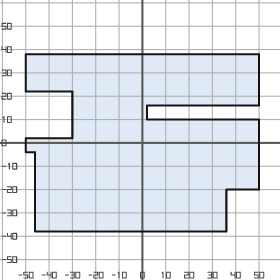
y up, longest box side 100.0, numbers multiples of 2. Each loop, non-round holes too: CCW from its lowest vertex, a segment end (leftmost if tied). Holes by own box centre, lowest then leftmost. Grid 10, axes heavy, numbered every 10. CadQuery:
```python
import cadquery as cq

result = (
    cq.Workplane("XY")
    .moveTo(-46.0, -38.0)
    .lineTo(36.0, -38.0)
    .lineTo(36.0, -20.0)
    .lineTo(50.0, -20.0)
    .lineTo(50.0, 10.0)
    .lineTo(2.0, 10.0)
    .lineTo(2.0, 16.0)
    .lineTo(50.0, 16.0)
    .lineTo(50.0, 38.0)
    .lineTo(-50.0, 38.0)
    .lineTo(-50.0, 22.0)
    .lineTo(-30.0, 22.0)
    .lineTo(-30.0, 2.0)
    .lineTo(-50.0, 2.0)
    .lineTo(-50.0, -4.0)
    .lineTo(-46.0, -4.0)
    .close()
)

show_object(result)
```